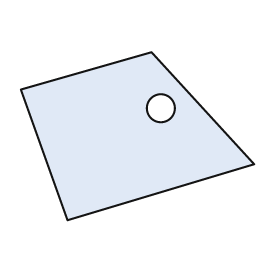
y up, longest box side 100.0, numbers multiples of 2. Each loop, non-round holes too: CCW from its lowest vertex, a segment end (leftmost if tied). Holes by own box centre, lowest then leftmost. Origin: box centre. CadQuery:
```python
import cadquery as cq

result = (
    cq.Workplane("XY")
    .moveTo(-30.0, -36.0)
    .lineTo(50.0, -12.0)
    .lineTo(6.0, 36.0)
    .lineTo(-50.0, 20.0)
    .close()
    .moveTo(10.0, 12.0)
    .circle(6.0)
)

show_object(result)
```